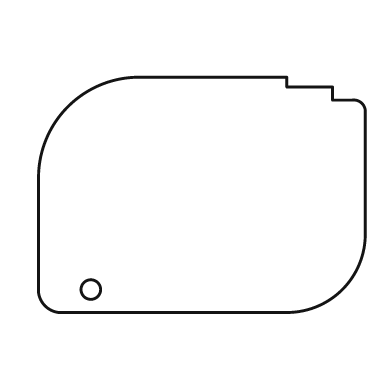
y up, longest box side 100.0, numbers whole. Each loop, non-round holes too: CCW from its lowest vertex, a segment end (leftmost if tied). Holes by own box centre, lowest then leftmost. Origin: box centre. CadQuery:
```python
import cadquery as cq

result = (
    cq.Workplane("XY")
    .moveTo(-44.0, -36.0)
    .lineTo(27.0, -36.0)
    .threePointArc((43.0, -29.0), (50.0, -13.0))
    .lineTo(50.0, 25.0)
    .threePointArc((49.0, 28.0), (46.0, 29.0))
    .lineTo(40.0, 29.0)
    .lineTo(40.0, 33.0)
    .lineTo(26.0, 33.0)
    .lineTo(26.0, 36.0)
    .lineTo(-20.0, 36.0)
    .threePointArc((-41.0, 27.0), (-50.0, 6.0))
    .lineTo(-50.0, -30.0)
    .threePointArc((-48.0, -34.0), (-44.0, -36.0))
    .close()
    .moveTo(-34.0, -29.0)
    .circle(3.0)
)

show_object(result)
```